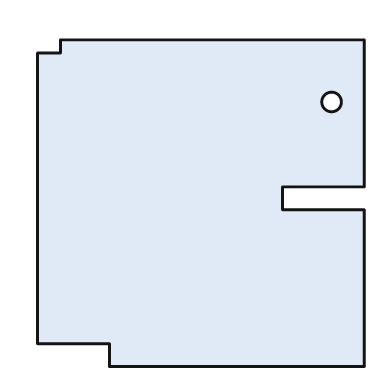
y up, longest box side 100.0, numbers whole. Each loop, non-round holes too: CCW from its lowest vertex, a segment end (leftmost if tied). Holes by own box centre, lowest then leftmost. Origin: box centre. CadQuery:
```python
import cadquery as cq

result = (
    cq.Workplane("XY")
    .moveTo(-28.0, -50.0)
    .lineTo(50.0, -50.0)
    .lineTo(50.0, -2.0)
    .lineTo(25.0, -2.0)
    .lineTo(25.0, 5.0)
    .lineTo(50.0, 5.0)
    .lineTo(50.0, 50.0)
    .lineTo(-43.0, 50.0)
    .lineTo(-43.0, 46.0)
    .lineTo(-50.0, 46.0)
    .lineTo(-50.0, -43.0)
    .lineTo(-28.0, -43.0)
    .close()
    .moveTo(40.0, 31.0)
    .circle(3.0)
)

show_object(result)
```